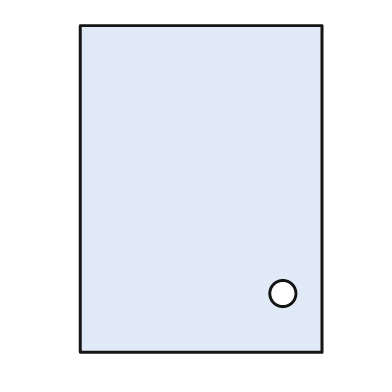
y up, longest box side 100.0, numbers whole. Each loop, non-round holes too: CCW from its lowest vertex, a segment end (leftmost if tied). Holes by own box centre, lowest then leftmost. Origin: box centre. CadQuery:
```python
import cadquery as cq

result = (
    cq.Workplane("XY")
    .moveTo(-37.0, -50.0)
    .lineTo(37.0, -50.0)
    .lineTo(37.0, 50.0)
    .lineTo(-37.0, 50.0)
    .close()
    .moveTo(25.0, -32.0)
    .circle(4.0)
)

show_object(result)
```